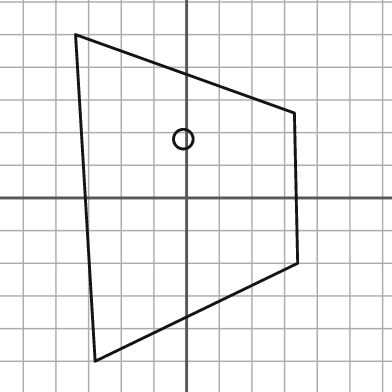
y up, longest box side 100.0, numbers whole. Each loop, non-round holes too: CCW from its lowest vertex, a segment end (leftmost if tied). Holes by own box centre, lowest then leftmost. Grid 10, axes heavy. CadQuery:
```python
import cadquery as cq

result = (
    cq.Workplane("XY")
    .moveTo(-28.0, -50.0)
    .lineTo(34.0, -20.0)
    .lineTo(33.0, 26.0)
    .lineTo(-34.0, 50.0)
    .close()
    .moveTo(-1.0, 18.0)
    .circle(3.0)
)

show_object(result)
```